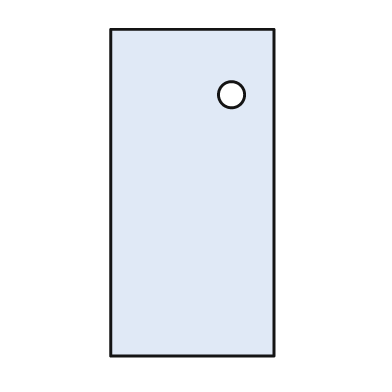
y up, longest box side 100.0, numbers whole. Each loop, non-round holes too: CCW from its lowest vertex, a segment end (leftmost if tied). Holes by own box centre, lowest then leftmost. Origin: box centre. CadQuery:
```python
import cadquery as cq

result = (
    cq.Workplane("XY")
    .moveTo(-25.0, -50.0)
    .lineTo(25.0, -50.0)
    .lineTo(25.0, 50.0)
    .lineTo(-25.0, 50.0)
    .close()
    .moveTo(12.0, 30.0)
    .circle(4.0)
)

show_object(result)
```